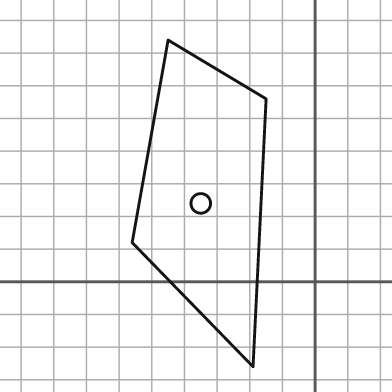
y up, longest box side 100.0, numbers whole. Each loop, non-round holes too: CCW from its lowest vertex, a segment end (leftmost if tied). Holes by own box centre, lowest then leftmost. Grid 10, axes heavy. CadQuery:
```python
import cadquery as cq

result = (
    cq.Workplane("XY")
    .moveTo(-19.0, -26.0)
    .lineTo(-15.0, 56.0)
    .lineTo(-45.0, 74.0)
    .lineTo(-56.0, 12.0)
    .close()
    .moveTo(-35.0, 24.0)
    .circle(3.0)
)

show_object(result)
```